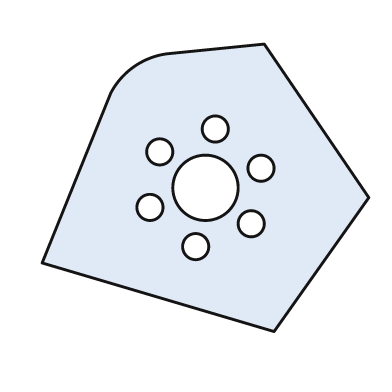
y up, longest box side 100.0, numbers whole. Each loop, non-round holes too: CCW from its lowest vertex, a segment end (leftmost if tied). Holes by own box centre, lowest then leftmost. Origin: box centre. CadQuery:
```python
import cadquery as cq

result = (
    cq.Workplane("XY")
    .moveTo(21.0, -44.0)
    .lineTo(50.0, -3.0)
    .lineTo(18.0, 44.0)
    .lineTo(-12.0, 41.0)
    .threePointArc((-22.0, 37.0), (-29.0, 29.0))
    .lineTo(-50.0, -23.0)
    .close()
    .moveTo(-3.0, -18.0)
    .circle(4.0)
    .moveTo(14.0, -11.0)
    .circle(4.0)
    .moveTo(-17.0, -6.0)
    .circle(4.0)
    .moveTo(0.0, 0.0)
    .circle(10.0)
    .moveTo(17.0, 6.0)
    .circle(4.0)
    .moveTo(-14.0, 11.0)
    .circle(4.0)
    .moveTo(3.0, 18.0)
    .circle(4.0)
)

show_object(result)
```